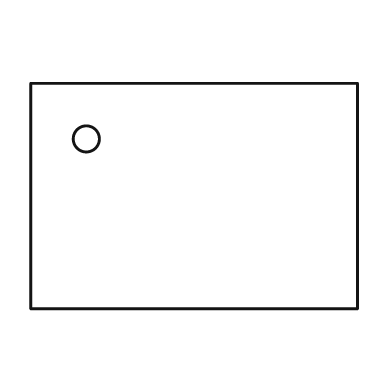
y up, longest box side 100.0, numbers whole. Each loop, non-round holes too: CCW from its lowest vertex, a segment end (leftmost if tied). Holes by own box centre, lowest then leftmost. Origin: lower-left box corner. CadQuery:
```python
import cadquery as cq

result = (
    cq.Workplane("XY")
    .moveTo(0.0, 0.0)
    .lineTo(100.0, 0.0)
    .lineTo(100.0, 69.0)
    .lineTo(0.0, 69.0)
    .close()
    .moveTo(17.0, 52.0)
    .circle(4.0)
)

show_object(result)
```